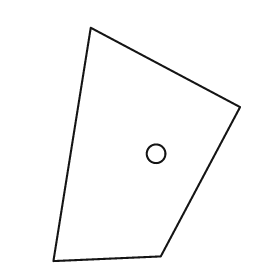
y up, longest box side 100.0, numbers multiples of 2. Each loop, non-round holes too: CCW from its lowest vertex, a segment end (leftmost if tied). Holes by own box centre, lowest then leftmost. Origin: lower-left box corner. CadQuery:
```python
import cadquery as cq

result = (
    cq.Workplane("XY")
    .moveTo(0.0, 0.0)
    .lineTo(46.0, 2.0)
    .lineTo(80.0, 66.0)
    .lineTo(16.0, 100.0)
    .close()
    .moveTo(44.0, 46.0)
    .circle(4.0)
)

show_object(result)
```